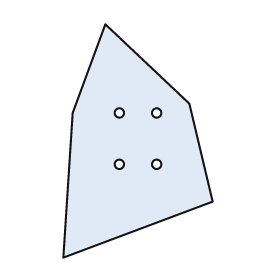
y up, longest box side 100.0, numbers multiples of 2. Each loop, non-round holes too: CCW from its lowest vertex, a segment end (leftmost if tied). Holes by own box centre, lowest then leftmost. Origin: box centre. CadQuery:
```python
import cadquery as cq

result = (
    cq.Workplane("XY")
    .moveTo(-32.0, -50.0)
    .lineTo(32.0, -26.0)
    .lineTo(22.0, 16.0)
    .lineTo(-14.0, 50.0)
    .lineTo(-28.0, 12.0)
    .close()
    .moveTo(-8.0, -10.0)
    .circle(2.0)
    .moveTo(8.0, -10.0)
    .circle(2.0)
    .moveTo(-8.0, 12.0)
    .circle(2.0)
    .moveTo(8.0, 12.0)
    .circle(2.0)
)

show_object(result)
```